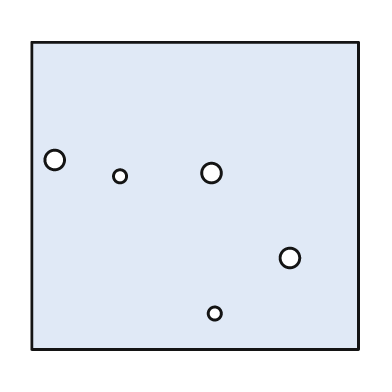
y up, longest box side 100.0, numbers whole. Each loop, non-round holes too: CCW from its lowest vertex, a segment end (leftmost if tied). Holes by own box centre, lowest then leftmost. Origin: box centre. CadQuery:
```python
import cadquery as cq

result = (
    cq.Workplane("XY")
    .moveTo(-50.0, -47.0)
    .lineTo(50.0, -47.0)
    .lineTo(50.0, 47.0)
    .lineTo(-50.0, 47.0)
    .close()
    .moveTo(6.0, -36.0)
    .circle(2.0)
    .moveTo(29.0, -19.0)
    .circle(3.0)
    .moveTo(-23.0, 6.0)
    .circle(2.0)
    .moveTo(5.0, 7.0)
    .circle(3.0)
    .moveTo(-43.0, 11.0)
    .circle(3.0)
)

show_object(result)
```